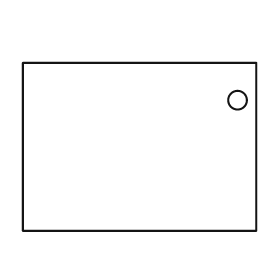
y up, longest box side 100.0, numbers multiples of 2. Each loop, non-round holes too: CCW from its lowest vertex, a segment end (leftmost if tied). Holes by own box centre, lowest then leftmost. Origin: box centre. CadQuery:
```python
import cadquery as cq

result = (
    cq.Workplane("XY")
    .moveTo(-50.0, -36.0)
    .lineTo(50.0, -36.0)
    .lineTo(50.0, 36.0)
    .lineTo(-50.0, 36.0)
    .close()
    .moveTo(42.0, 20.0)
    .circle(4.0)
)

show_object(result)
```